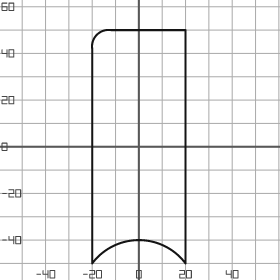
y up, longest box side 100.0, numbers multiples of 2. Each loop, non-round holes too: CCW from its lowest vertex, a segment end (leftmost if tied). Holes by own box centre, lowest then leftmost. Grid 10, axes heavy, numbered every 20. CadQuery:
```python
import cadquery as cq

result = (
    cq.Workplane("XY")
    .moveTo(-20.0, -50.0)
    .threePointArc((0.0, -40.0), (20.0, -50.0))
    .lineTo(20.0, 50.0)
    .lineTo(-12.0, 50.0)
    .threePointArc((-18.0, 48.0), (-20.0, 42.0))
    .close()
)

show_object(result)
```